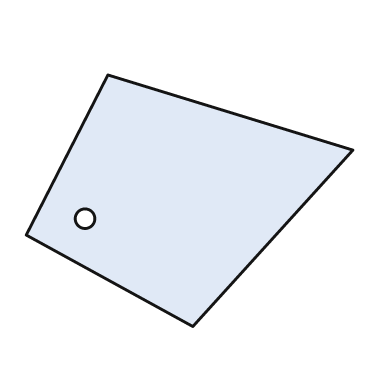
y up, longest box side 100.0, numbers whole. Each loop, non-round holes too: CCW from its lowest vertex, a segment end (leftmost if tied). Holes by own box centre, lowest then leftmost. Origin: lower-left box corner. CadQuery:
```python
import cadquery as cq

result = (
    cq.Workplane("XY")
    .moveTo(51.0, 0.0)
    .lineTo(100.0, 54.0)
    .lineTo(25.0, 77.0)
    .lineTo(0.0, 28.0)
    .close()
    .moveTo(18.0, 33.0)
    .circle(3.0)
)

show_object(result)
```